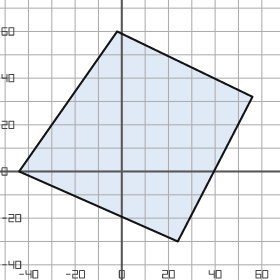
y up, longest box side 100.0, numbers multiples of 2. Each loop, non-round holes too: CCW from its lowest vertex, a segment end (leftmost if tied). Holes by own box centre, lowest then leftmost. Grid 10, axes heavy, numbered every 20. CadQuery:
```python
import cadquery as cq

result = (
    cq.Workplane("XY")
    .moveTo(24.0, -30.0)
    .lineTo(56.0, 32.0)
    .lineTo(-2.0, 60.0)
    .lineTo(-44.0, 0.0)
    .close()
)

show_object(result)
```